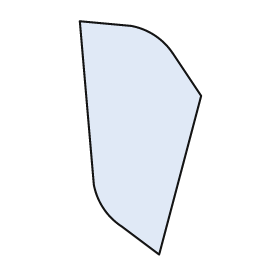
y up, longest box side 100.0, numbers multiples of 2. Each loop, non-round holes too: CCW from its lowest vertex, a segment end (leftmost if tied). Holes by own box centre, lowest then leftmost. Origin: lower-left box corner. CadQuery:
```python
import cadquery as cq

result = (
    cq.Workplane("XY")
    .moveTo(34.0, 0.0)
    .lineTo(52.0, 68.0)
    .lineTo(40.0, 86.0)
    .threePointArc((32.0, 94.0), (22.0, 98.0))
    .lineTo(0.0, 100.0)
    .lineTo(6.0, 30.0)
    .threePointArc((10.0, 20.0), (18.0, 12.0))
    .close()
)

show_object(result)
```